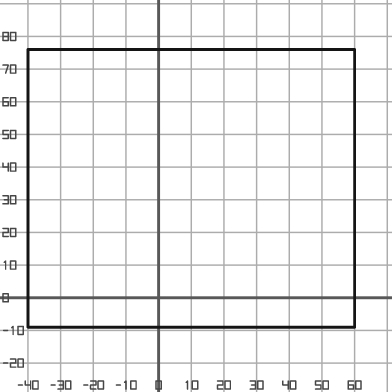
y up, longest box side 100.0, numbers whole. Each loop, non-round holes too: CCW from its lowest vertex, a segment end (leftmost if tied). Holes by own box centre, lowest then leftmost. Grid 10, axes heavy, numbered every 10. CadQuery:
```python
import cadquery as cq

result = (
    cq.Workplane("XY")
    .moveTo(-40.0, -9.0)
    .lineTo(60.0, -9.0)
    .lineTo(60.0, 76.0)
    .lineTo(-40.0, 76.0)
    .close()
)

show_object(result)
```